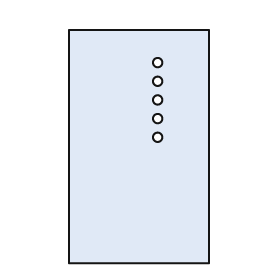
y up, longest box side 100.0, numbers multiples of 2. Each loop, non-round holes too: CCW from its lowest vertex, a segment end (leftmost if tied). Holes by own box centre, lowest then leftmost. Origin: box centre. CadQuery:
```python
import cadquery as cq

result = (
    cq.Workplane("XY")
    .moveTo(-30.0, -50.0)
    .lineTo(30.0, -50.0)
    .lineTo(30.0, 50.0)
    .lineTo(-30.0, 50.0)
    .close()
    .moveTo(8.0, 4.0)
    .circle(2.0)
    .moveTo(8.0, 12.0)
    .circle(2.0)
    .moveTo(8.0, 20.0)
    .circle(2.0)
    .moveTo(8.0, 28.0)
    .circle(2.0)
    .moveTo(8.0, 36.0)
    .circle(2.0)
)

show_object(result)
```